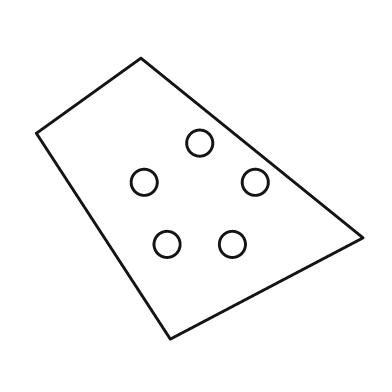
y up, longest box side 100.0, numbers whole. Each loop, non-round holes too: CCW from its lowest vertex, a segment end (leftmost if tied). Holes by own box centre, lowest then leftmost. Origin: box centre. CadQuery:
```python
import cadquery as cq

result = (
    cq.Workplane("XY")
    .moveTo(-9.0, -43.0)
    .lineTo(50.0, -12.0)
    .lineTo(-18.0, 43.0)
    .lineTo(-50.0, 20.0)
    .close()
    .moveTo(-10.0, -14.0)
    .circle(4.0)
    .moveTo(10.0, -14.0)
    .circle(4.0)
    .moveTo(-17.0, 5.0)
    .circle(4.0)
    .moveTo(17.0, 5.0)
    .circle(4.0)
    .moveTo(0.0, 17.0)
    .circle(4.0)
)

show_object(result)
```